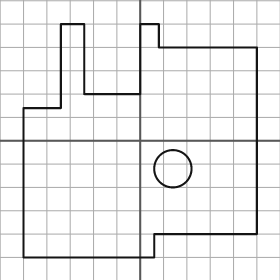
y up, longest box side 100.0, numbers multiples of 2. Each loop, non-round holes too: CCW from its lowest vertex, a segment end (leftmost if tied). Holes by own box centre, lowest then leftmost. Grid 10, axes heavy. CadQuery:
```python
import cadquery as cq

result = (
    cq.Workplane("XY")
    .moveTo(-50.0, -50.0)
    .lineTo(6.0, -50.0)
    .lineTo(6.0, -40.0)
    .lineTo(50.0, -40.0)
    .lineTo(50.0, 40.0)
    .lineTo(8.0, 40.0)
    .lineTo(8.0, 50.0)
    .lineTo(0.0, 50.0)
    .lineTo(0.0, 20.0)
    .lineTo(-24.0, 20.0)
    .lineTo(-24.0, 50.0)
    .lineTo(-34.0, 50.0)
    .lineTo(-34.0, 14.0)
    .lineTo(-50.0, 14.0)
    .close()
    .moveTo(14.0, -12.0)
    .circle(8.0)
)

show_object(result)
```